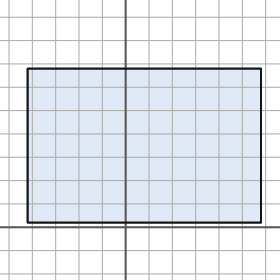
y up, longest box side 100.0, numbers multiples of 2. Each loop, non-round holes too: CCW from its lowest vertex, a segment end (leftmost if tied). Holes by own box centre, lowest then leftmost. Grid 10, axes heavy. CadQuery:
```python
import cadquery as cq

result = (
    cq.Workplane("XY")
    .moveTo(-42.0, 2.0)
    .lineTo(58.0, 2.0)
    .lineTo(58.0, 68.0)
    .lineTo(-42.0, 68.0)
    .close()
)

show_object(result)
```